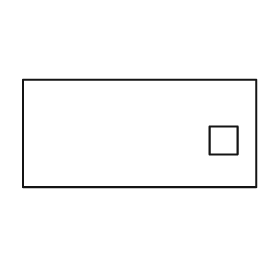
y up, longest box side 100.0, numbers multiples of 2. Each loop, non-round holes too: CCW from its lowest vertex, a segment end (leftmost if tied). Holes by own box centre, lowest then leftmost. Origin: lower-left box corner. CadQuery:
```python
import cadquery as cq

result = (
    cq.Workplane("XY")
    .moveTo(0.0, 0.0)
    .lineTo(100.0, 0.0)
    .lineTo(100.0, 46.0)
    .lineTo(0.0, 46.0)
    .close()
    .moveTo(80.0, 14.0)
    .lineTo(92.0, 14.0)
    .lineTo(92.0, 26.0)
    .lineTo(80.0, 26.0)
    .close()
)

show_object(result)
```